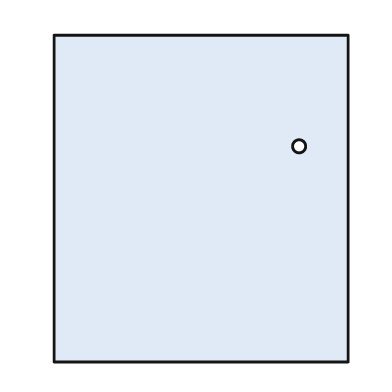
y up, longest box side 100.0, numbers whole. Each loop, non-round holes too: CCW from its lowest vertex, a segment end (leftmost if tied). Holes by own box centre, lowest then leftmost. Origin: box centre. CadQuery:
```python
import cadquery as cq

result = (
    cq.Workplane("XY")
    .moveTo(-45.0, -50.0)
    .lineTo(45.0, -50.0)
    .lineTo(45.0, 50.0)
    .lineTo(-45.0, 50.0)
    .close()
    .moveTo(30.0, 16.0)
    .circle(2.0)
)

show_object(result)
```